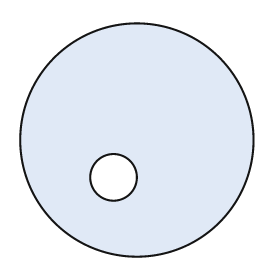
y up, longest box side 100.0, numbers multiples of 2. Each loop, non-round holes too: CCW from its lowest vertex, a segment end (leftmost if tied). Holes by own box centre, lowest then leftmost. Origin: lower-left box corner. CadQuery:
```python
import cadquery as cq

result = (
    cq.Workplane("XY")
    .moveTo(50.0, 50.0)
    .circle(50.0)
    .moveTo(40.0, 34.0)
    .circle(10.0)
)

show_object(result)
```